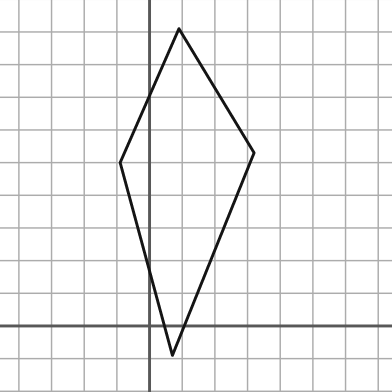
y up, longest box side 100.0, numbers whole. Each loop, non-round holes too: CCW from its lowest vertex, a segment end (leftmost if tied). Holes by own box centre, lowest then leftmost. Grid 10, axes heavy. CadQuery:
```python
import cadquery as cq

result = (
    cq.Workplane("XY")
    .moveTo(7.0, -9.0)
    .lineTo(32.0, 53.0)
    .lineTo(9.0, 91.0)
    .lineTo(-9.0, 50.0)
    .close()
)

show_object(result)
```